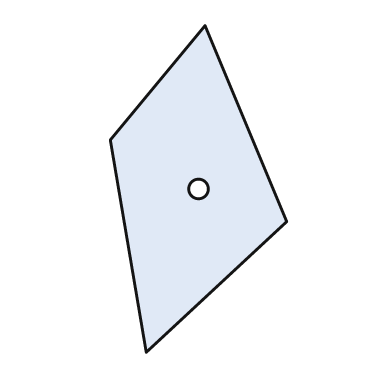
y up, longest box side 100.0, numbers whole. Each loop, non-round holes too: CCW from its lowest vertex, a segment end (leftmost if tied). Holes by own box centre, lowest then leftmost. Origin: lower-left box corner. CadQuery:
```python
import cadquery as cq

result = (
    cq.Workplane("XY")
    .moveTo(11.0, 0.0)
    .lineTo(54.0, 40.0)
    .lineTo(29.0, 100.0)
    .lineTo(0.0, 65.0)
    .close()
    .moveTo(27.0, 50.0)
    .circle(3.0)
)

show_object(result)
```